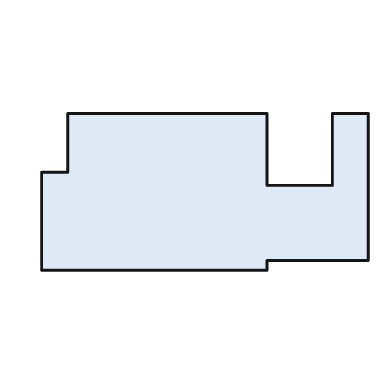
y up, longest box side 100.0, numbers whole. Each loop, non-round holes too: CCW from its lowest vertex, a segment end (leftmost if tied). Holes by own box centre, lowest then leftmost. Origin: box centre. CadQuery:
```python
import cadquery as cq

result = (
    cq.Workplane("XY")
    .moveTo(-50.0, -24.0)
    .lineTo(19.0, -24.0)
    .lineTo(19.0, -21.0)
    .lineTo(50.0, -21.0)
    .lineTo(50.0, 24.0)
    .lineTo(39.0, 24.0)
    .lineTo(39.0, 2.0)
    .lineTo(19.0, 2.0)
    .lineTo(19.0, 24.0)
    .lineTo(-42.0, 24.0)
    .lineTo(-42.0, 6.0)
    .lineTo(-50.0, 6.0)
    .close()
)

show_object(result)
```